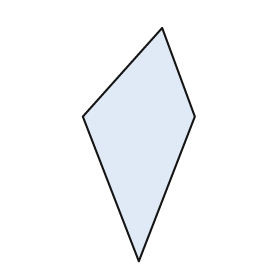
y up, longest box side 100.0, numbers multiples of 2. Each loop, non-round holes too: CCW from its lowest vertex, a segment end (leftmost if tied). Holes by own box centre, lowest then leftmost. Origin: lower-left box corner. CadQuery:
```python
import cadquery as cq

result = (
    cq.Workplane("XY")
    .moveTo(24.0, 0.0)
    .lineTo(48.0, 62.0)
    .lineTo(34.0, 100.0)
    .lineTo(0.0, 62.0)
    .close()
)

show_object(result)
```